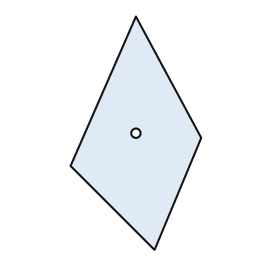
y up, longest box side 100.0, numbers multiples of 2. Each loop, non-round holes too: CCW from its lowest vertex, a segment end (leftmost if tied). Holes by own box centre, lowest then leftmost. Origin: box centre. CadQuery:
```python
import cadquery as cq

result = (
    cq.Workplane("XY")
    .moveTo(8.0, -50.0)
    .lineTo(28.0, -2.0)
    .lineTo(0.0, 50.0)
    .lineTo(-28.0, -14.0)
    .close()
    .moveTo(0.0, 0.0)
    .circle(2.0)
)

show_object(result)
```